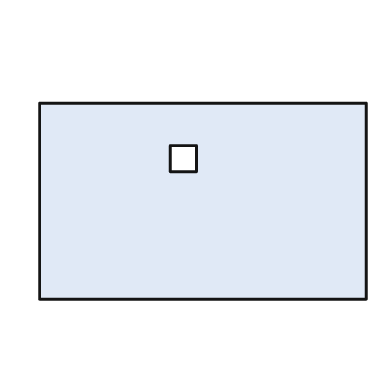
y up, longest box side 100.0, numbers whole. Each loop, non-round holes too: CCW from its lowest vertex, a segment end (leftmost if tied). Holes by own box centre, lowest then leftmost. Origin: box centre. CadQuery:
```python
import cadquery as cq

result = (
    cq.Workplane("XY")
    .moveTo(-50.0, -30.0)
    .lineTo(50.0, -30.0)
    .lineTo(50.0, 30.0)
    .lineTo(-50.0, 30.0)
    .close()
    .moveTo(-10.0, 9.0)
    .lineTo(-2.0, 9.0)
    .lineTo(-2.0, 17.0)
    .lineTo(-10.0, 17.0)
    .close()
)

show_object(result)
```